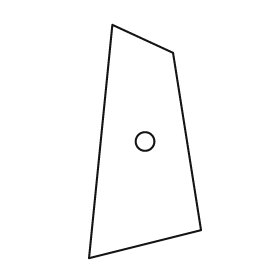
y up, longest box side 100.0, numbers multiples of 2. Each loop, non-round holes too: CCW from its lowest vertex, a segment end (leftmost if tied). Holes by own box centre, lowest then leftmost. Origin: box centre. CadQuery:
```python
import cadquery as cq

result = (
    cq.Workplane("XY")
    .moveTo(-24.0, -50.0)
    .lineTo(24.0, -38.0)
    .lineTo(12.0, 38.0)
    .lineTo(-14.0, 50.0)
    .close()
    .moveTo(0.0, 0.0)
    .circle(4.0)
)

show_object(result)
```